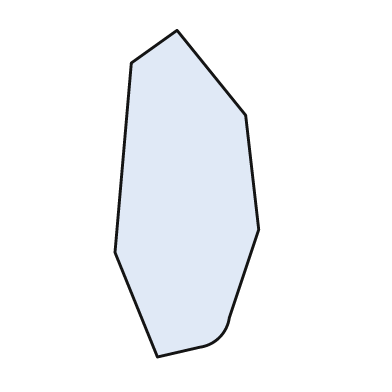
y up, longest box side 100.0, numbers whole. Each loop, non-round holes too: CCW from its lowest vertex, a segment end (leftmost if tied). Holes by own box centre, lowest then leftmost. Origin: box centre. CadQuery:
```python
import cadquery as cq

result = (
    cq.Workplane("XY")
    .moveTo(-9.0, -50.0)
    .lineTo(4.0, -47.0)
    .threePointArc((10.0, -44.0), (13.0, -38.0))
    .lineTo(22.0, -11.0)
    .lineTo(18.0, 24.0)
    .lineTo(-3.0, 50.0)
    .lineTo(-17.0, 40.0)
    .lineTo(-22.0, -18.0)
    .close()
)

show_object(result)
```